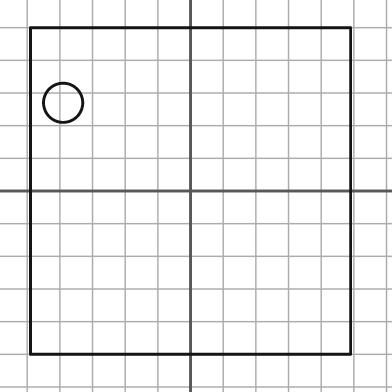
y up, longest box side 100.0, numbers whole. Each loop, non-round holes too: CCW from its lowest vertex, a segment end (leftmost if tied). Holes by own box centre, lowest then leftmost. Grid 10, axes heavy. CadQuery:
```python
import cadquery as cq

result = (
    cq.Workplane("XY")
    .moveTo(-49.0, -50.0)
    .lineTo(49.0, -50.0)
    .lineTo(49.0, 50.0)
    .lineTo(-49.0, 50.0)
    .close()
    .moveTo(-39.0, 27.0)
    .circle(6.0)
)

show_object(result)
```